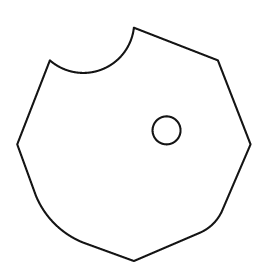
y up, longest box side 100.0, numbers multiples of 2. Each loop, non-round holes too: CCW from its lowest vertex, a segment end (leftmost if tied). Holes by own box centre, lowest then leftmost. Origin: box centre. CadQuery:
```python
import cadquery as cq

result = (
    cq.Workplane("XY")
    .moveTo(0.0, -50.0)
    .lineTo(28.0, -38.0)
    .threePointArc((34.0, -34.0), (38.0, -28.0))
    .lineTo(50.0, 0.0)
    .lineTo(36.0, 36.0)
    .lineTo(0.0, 50.0)
    .threePointArc((-14.0, 32.0), (-36.0, 36.0))
    .lineTo(-50.0, 0.0)
    .lineTo(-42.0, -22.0)
    .threePointArc((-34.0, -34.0), (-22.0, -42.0))
    .close()
    .moveTo(14.0, 6.0)
    .circle(6.0)
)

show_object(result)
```